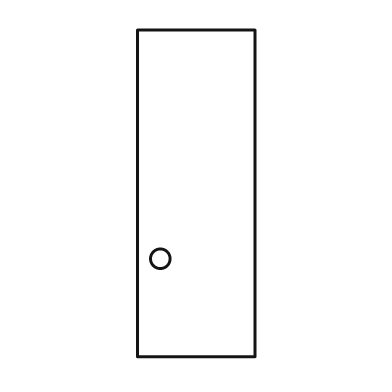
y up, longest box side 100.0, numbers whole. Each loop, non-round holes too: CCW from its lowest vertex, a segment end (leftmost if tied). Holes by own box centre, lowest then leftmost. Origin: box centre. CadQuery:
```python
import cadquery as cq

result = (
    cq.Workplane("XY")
    .moveTo(-18.0, -50.0)
    .lineTo(18.0, -50.0)
    .lineTo(18.0, 50.0)
    .lineTo(-18.0, 50.0)
    .close()
    .moveTo(-11.0, -20.0)
    .circle(3.0)
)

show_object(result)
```